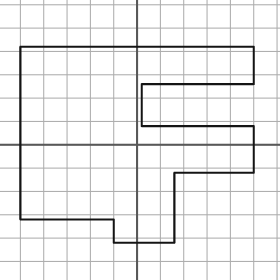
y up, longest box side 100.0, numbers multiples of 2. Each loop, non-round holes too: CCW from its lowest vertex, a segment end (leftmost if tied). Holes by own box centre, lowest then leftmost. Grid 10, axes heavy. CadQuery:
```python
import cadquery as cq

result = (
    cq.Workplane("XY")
    .moveTo(-10.0, -42.0)
    .lineTo(16.0, -42.0)
    .lineTo(16.0, -12.0)
    .lineTo(50.0, -12.0)
    .lineTo(50.0, 8.0)
    .lineTo(2.0, 8.0)
    .lineTo(2.0, 26.0)
    .lineTo(50.0, 26.0)
    .lineTo(50.0, 42.0)
    .lineTo(-50.0, 42.0)
    .lineTo(-50.0, -32.0)
    .lineTo(-10.0, -32.0)
    .close()
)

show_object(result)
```